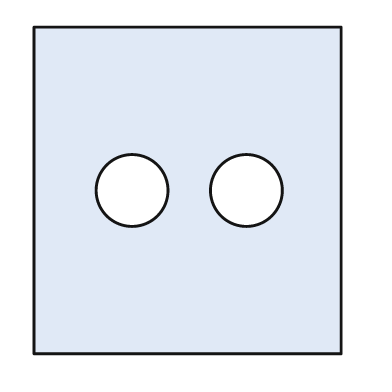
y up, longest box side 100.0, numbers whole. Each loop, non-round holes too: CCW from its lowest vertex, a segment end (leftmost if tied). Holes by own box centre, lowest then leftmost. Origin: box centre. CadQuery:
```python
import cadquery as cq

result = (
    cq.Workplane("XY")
    .moveTo(-47.0, -50.0)
    .lineTo(47.0, -50.0)
    .lineTo(47.0, 50.0)
    .lineTo(-47.0, 50.0)
    .close()
    .moveTo(-17.0, 0.0)
    .circle(11.0)
    .moveTo(18.0, 0.0)
    .circle(11.0)
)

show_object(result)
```